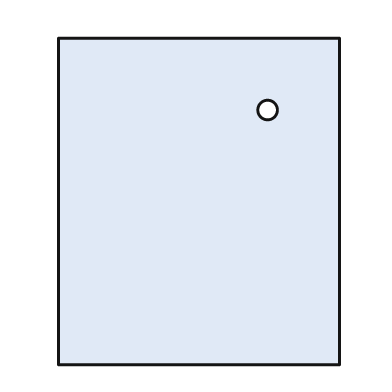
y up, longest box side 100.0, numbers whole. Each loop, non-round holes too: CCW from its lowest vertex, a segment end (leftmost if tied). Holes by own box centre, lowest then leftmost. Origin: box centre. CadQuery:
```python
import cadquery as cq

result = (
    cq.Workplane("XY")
    .moveTo(-43.0, -50.0)
    .lineTo(43.0, -50.0)
    .lineTo(43.0, 50.0)
    .lineTo(-43.0, 50.0)
    .close()
    .moveTo(21.0, 28.0)
    .circle(3.0)
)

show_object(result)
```